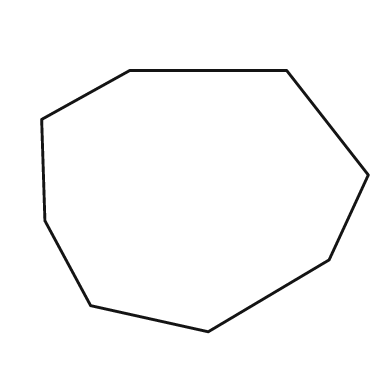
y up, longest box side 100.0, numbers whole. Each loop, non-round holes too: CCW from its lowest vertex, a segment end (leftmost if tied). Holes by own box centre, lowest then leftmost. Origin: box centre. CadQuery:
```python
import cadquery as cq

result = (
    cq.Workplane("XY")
    .moveTo(1.0, -40.0)
    .lineTo(38.0, -18.0)
    .lineTo(50.0, 8.0)
    .lineTo(25.0, 40.0)
    .lineTo(-23.0, 40.0)
    .lineTo(-50.0, 25.0)
    .lineTo(-49.0, -6.0)
    .lineTo(-35.0, -32.0)
    .close()
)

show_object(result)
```